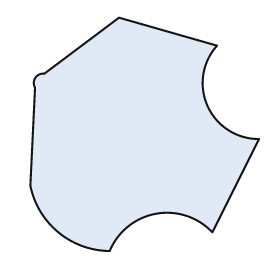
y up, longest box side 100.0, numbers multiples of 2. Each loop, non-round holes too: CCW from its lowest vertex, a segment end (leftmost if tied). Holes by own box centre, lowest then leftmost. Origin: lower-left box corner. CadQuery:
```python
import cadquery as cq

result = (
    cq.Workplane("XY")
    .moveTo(34.0, 0.0)
    .threePointArc((54.0, 16.0), (78.0, 8.0))
    .lineTo(98.0, 48.0)
    .threePointArc((76.0, 62.0), (80.0, 88.0))
    .lineTo(38.0, 100.0)
    .lineTo(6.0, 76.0)
    .threePointArc((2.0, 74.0), (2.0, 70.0))
    .lineTo(0.0, 28.0)
    .threePointArc((12.0, 8.0), (34.0, 0.0))
    .close()
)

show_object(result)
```